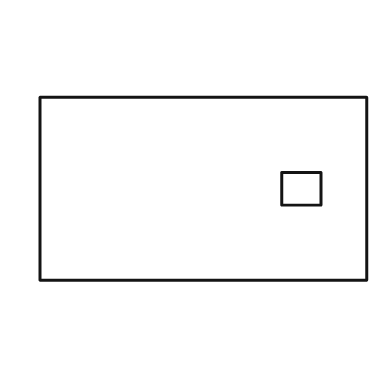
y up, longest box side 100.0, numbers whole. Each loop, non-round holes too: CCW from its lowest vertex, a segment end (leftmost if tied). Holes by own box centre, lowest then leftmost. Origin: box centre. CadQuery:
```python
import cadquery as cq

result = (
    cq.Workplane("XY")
    .moveTo(-50.0, -28.0)
    .lineTo(50.0, -28.0)
    .lineTo(50.0, 28.0)
    .lineTo(-50.0, 28.0)
    .close()
    .moveTo(24.0, -5.0)
    .lineTo(36.0, -5.0)
    .lineTo(36.0, 5.0)
    .lineTo(24.0, 5.0)
    .close()
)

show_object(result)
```